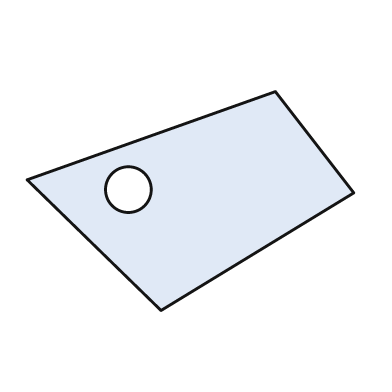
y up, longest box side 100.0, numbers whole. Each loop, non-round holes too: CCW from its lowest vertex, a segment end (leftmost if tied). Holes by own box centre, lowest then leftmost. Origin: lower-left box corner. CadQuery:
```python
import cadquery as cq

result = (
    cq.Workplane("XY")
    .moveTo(41.0, 0.0)
    .lineTo(100.0, 36.0)
    .lineTo(76.0, 67.0)
    .lineTo(0.0, 40.0)
    .close()
    .moveTo(31.0, 37.0)
    .circle(7.0)
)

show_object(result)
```